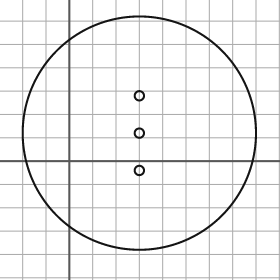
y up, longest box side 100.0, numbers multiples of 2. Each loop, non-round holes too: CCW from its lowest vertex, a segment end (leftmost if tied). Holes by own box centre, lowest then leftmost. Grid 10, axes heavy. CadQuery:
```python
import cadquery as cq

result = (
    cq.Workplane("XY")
    .moveTo(30.0, 12.0)
    .circle(50.0)
    .moveTo(30.0, -4.0)
    .circle(2.0)
    .moveTo(30.0, 12.0)
    .circle(2.0)
    .moveTo(30.0, 28.0)
    .circle(2.0)
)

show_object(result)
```